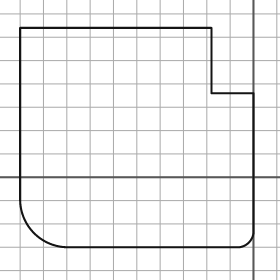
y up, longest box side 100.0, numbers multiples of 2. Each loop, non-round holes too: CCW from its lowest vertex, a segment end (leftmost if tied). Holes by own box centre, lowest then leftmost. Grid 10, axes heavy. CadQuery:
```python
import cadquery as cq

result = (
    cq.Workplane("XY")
    .moveTo(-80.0, -30.0)
    .lineTo(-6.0, -30.0)
    .threePointArc((-2.0, -28.0), (0.0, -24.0))
    .lineTo(0.0, 36.0)
    .lineTo(-18.0, 36.0)
    .lineTo(-18.0, 64.0)
    .lineTo(-100.0, 64.0)
    .lineTo(-100.0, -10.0)
    .threePointArc((-94.0, -24.0), (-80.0, -30.0))
    .close()
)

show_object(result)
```